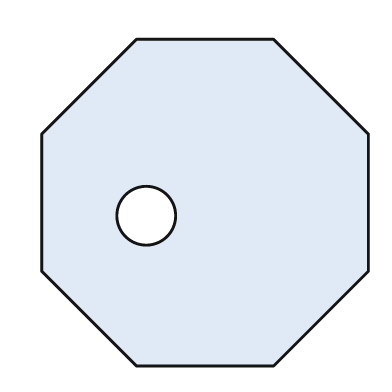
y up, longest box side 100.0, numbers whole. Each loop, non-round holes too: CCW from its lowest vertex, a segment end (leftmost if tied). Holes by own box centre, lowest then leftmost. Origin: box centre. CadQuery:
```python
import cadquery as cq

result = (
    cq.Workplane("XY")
    .moveTo(-21.0, -50.0)
    .lineTo(21.0, -50.0)
    .lineTo(50.0, -21.0)
    .lineTo(50.0, 21.0)
    .lineTo(21.0, 50.0)
    .lineTo(-21.0, 50.0)
    .lineTo(-50.0, 21.0)
    .lineTo(-50.0, -21.0)
    .close()
    .moveTo(-18.0, -4.0)
    .circle(9.0)
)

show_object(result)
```